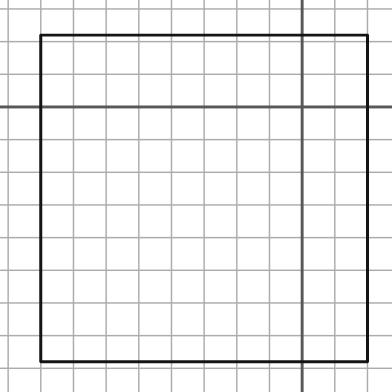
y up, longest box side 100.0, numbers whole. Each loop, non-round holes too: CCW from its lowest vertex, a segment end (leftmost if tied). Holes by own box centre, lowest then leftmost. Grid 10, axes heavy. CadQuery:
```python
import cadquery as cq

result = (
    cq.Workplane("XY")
    .moveTo(-80.0, -78.0)
    .lineTo(20.0, -78.0)
    .lineTo(20.0, 22.0)
    .lineTo(-80.0, 22.0)
    .close()
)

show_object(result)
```